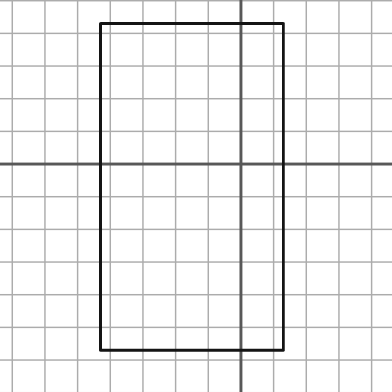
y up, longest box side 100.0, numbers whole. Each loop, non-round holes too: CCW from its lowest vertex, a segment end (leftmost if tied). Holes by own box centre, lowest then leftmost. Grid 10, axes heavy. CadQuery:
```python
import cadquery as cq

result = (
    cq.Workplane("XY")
    .moveTo(-43.0, -57.0)
    .lineTo(13.0, -57.0)
    .lineTo(13.0, 43.0)
    .lineTo(-43.0, 43.0)
    .close()
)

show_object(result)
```